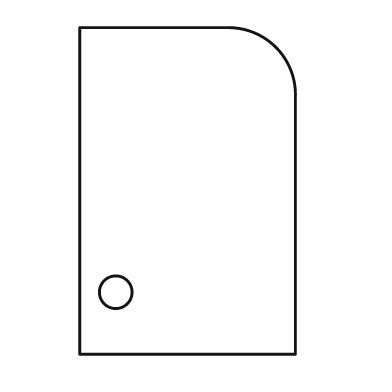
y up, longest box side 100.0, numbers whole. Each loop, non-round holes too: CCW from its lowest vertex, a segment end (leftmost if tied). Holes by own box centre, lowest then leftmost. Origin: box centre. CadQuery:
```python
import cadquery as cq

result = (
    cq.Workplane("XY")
    .moveTo(-33.0, -50.0)
    .lineTo(33.0, -50.0)
    .lineTo(33.0, 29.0)
    .threePointArc((27.0, 44.0), (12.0, 50.0))
    .lineTo(-33.0, 50.0)
    .close()
    .moveTo(-22.0, -31.0)
    .circle(5.0)
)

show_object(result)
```